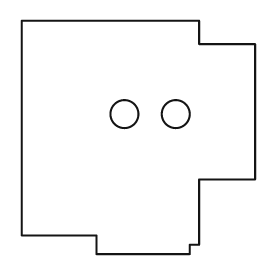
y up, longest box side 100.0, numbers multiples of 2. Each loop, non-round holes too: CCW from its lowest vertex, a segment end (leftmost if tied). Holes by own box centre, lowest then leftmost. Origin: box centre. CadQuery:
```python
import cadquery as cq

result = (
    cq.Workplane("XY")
    .moveTo(-18.0, -50.0)
    .lineTo(22.0, -50.0)
    .lineTo(22.0, -46.0)
    .lineTo(26.0, -46.0)
    .lineTo(26.0, -18.0)
    .lineTo(50.0, -18.0)
    .lineTo(50.0, 40.0)
    .lineTo(26.0, 40.0)
    .lineTo(26.0, 50.0)
    .lineTo(-50.0, 50.0)
    .lineTo(-50.0, -42.0)
    .lineTo(-18.0, -42.0)
    .close()
    .moveTo(-6.0, 10.0)
    .circle(6.0)
    .moveTo(16.0, 10.0)
    .circle(6.0)
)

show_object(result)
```